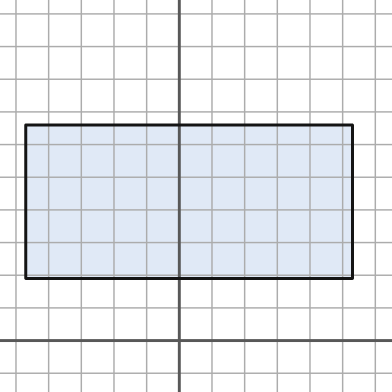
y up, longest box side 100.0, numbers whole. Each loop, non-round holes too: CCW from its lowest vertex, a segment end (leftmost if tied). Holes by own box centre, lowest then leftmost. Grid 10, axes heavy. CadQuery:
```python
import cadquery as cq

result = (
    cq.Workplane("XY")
    .moveTo(-47.0, 19.0)
    .lineTo(53.0, 19.0)
    .lineTo(53.0, 66.0)
    .lineTo(-47.0, 66.0)
    .close()
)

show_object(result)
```